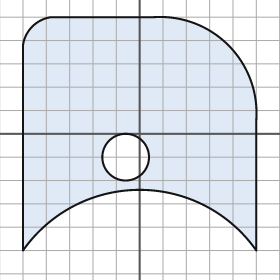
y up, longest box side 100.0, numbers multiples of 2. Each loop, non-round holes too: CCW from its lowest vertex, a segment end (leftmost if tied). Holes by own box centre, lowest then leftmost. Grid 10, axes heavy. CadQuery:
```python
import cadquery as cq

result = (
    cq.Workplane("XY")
    .moveTo(-50.0, -50.0)
    .threePointArc((0.0, -24.0), (50.0, -50.0))
    .lineTo(50.0, 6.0)
    .threePointArc((38.0, 38.0), (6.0, 50.0))
    .lineTo(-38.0, 50.0)
    .threePointArc((-46.0, 46.0), (-50.0, 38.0))
    .close()
    .moveTo(-6.0, -10.0)
    .circle(10.0)
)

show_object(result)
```